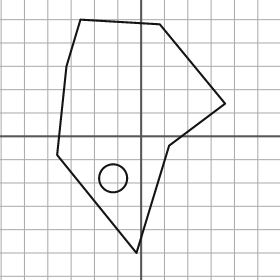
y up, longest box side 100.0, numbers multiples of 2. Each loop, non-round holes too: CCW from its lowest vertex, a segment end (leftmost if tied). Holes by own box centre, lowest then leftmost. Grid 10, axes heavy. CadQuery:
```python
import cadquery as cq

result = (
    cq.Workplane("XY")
    .moveTo(-2.0, -50.0)
    .lineTo(12.0, -4.0)
    .lineTo(36.0, 14.0)
    .lineTo(8.0, 48.0)
    .lineTo(-26.0, 50.0)
    .lineTo(-32.0, 30.0)
    .lineTo(-36.0, -8.0)
    .close()
    .moveTo(-12.0, -18.0)
    .circle(6.0)
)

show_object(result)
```